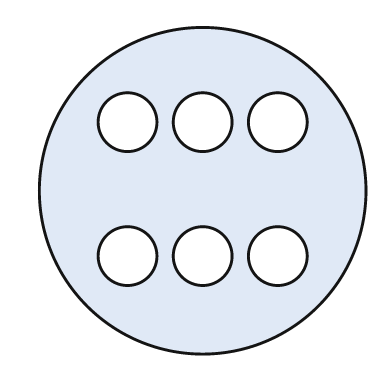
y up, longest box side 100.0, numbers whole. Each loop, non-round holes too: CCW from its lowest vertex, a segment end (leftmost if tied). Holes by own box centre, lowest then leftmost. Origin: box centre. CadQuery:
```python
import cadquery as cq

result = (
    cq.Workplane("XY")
    .moveTo(0.0, 0.0)
    .circle(50.0)
    .moveTo(-23.0, -20.0)
    .circle(9.0)
    .moveTo(0.0, -20.0)
    .circle(9.0)
    .moveTo(23.0, -20.0)
    .circle(9.0)
    .moveTo(-23.0, 21.0)
    .circle(9.0)
    .moveTo(0.0, 21.0)
    .circle(9.0)
    .moveTo(23.0, 21.0)
    .circle(9.0)
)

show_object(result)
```